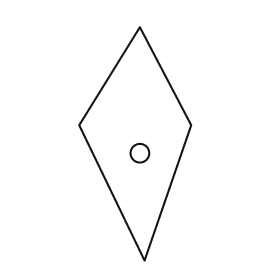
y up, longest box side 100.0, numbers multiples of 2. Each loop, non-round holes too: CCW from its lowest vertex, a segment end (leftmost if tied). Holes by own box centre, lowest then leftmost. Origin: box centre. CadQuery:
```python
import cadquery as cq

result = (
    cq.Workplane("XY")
    .moveTo(4.0, -50.0)
    .lineTo(24.0, 8.0)
    .lineTo(2.0, 50.0)
    .lineTo(-24.0, 8.0)
    .close()
    .moveTo(2.0, -4.0)
    .circle(4.0)
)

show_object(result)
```